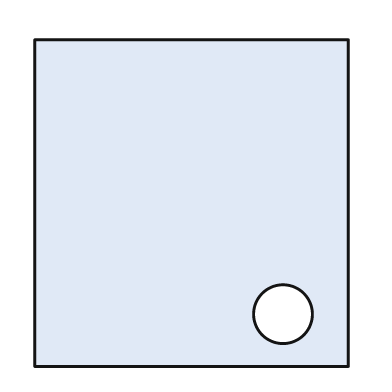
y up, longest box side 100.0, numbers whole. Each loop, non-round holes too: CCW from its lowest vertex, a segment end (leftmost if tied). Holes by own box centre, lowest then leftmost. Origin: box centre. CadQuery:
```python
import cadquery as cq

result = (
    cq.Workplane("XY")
    .moveTo(-48.0, -50.0)
    .lineTo(48.0, -50.0)
    .lineTo(48.0, 50.0)
    .lineTo(-48.0, 50.0)
    .close()
    .moveTo(28.0, -34.0)
    .circle(9.0)
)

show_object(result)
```